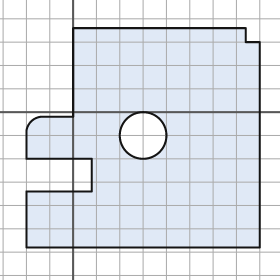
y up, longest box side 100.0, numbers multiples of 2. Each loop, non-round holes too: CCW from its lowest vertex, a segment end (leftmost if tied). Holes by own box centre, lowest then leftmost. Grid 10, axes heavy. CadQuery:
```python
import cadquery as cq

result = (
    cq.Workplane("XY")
    .moveTo(-20.0, -58.0)
    .lineTo(80.0, -58.0)
    .lineTo(80.0, 30.0)
    .lineTo(74.0, 30.0)
    .lineTo(74.0, 36.0)
    .lineTo(0.0, 36.0)
    .lineTo(0.0, -2.0)
    .lineTo(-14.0, -2.0)
    .threePointArc((-18.0, -4.0), (-20.0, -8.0))
    .lineTo(-20.0, -20.0)
    .lineTo(8.0, -20.0)
    .lineTo(8.0, -34.0)
    .lineTo(-20.0, -34.0)
    .close()
    .moveTo(30.0, -10.0)
    .circle(10.0)
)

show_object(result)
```